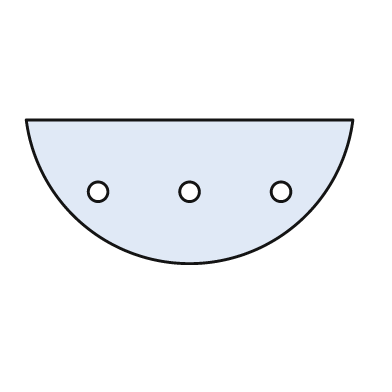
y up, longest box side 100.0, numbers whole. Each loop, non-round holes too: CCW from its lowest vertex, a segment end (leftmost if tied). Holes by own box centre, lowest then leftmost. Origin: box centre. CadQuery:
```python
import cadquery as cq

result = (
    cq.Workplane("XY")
    .moveTo(-50.0, 22.0)
    .threePointArc((0.0, -22.0), (50.0, 22.0))
    .close()
    .moveTo(-28.0, 0.0)
    .circle(3.0)
    .moveTo(0.0, 0.0)
    .circle(3.0)
    .moveTo(28.0, 0.0)
    .circle(3.0)
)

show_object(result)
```